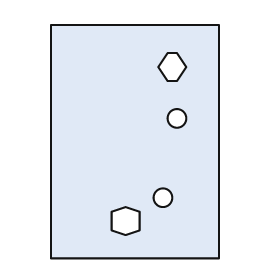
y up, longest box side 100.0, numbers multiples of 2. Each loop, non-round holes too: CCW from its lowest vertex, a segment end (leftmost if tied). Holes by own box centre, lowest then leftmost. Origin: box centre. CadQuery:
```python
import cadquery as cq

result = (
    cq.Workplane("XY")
    .moveTo(-36.0, -50.0)
    .lineTo(36.0, -50.0)
    .lineTo(36.0, 50.0)
    .lineTo(-36.0, 50.0)
    .close()
    .moveTo(-4.0, -40.0)
    .lineTo(2.0, -38.0)
    .lineTo(2.0, -30.0)
    .lineTo(-4.0, -28.0)
    .lineTo(-10.0, -30.0)
    .lineTo(-10.0, -38.0)
    .close()
    .moveTo(12.0, -24.0)
    .circle(4.0)
    .moveTo(18.0, 10.0)
    .circle(4.0)
    .moveTo(14.0, 26.0)
    .lineTo(18.0, 26.0)
    .lineTo(22.0, 32.0)
    .lineTo(18.0, 38.0)
    .lineTo(14.0, 38.0)
    .lineTo(10.0, 32.0)
    .close()
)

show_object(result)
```